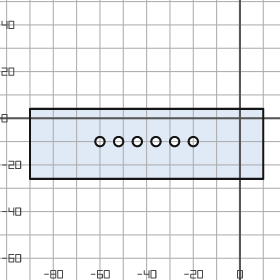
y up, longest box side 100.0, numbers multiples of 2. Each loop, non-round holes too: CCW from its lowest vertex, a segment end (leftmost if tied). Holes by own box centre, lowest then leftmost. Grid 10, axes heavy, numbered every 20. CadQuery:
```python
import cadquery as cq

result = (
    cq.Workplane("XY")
    .moveTo(-90.0, -26.0)
    .lineTo(10.0, -26.0)
    .lineTo(10.0, 4.0)
    .lineTo(-90.0, 4.0)
    .close()
    .moveTo(-60.0, -10.0)
    .circle(2.0)
    .moveTo(-52.0, -10.0)
    .circle(2.0)
    .moveTo(-44.0, -10.0)
    .circle(2.0)
    .moveTo(-36.0, -10.0)
    .circle(2.0)
    .moveTo(-28.0, -10.0)
    .circle(2.0)
    .moveTo(-20.0, -10.0)
    .circle(2.0)
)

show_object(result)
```